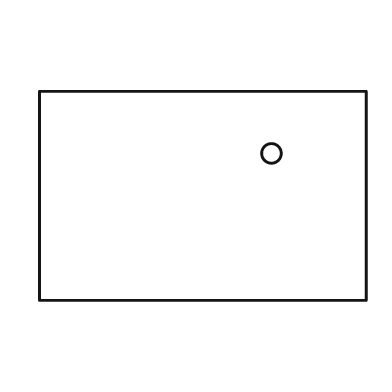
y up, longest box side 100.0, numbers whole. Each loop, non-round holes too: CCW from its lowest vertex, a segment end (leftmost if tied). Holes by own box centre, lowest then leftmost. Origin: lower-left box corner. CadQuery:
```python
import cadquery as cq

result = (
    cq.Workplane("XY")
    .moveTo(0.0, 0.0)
    .lineTo(100.0, 0.0)
    .lineTo(100.0, 64.0)
    .lineTo(0.0, 64.0)
    .close()
    .moveTo(71.0, 45.0)
    .circle(3.0)
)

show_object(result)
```